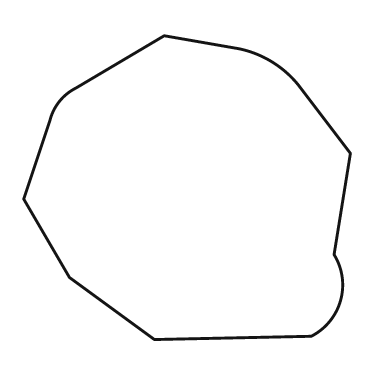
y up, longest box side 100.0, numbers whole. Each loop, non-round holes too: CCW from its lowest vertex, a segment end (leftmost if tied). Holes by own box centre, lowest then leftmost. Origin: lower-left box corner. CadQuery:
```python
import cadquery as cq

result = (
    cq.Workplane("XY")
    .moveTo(40.0, 0.0)
    .lineTo(88.0, 1.0)
    .threePointArc((97.0, 12.0), (95.0, 26.0))
    .lineTo(100.0, 57.0)
    .lineTo(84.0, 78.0)
    .threePointArc((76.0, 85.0), (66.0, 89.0))
    .lineTo(43.0, 93.0)
    .lineTo(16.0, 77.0)
    .threePointArc((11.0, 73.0), (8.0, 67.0))
    .lineTo(0.0, 43.0)
    .lineTo(14.0, 19.0)
    .close()
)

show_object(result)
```